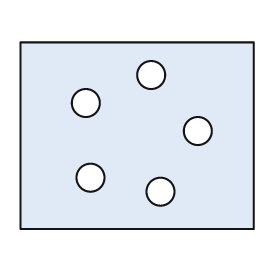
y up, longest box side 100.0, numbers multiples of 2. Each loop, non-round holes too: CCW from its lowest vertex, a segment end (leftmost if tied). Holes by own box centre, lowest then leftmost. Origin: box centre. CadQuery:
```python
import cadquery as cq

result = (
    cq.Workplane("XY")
    .moveTo(-50.0, -40.0)
    .lineTo(50.0, -40.0)
    .lineTo(50.0, 40.0)
    .lineTo(-50.0, 40.0)
    .close()
    .moveTo(10.0, -24.0)
    .circle(6.0)
    .moveTo(-20.0, -18.0)
    .circle(6.0)
    .moveTo(26.0, 2.0)
    .circle(6.0)
    .moveTo(-22.0, 14.0)
    .circle(6.0)
    .moveTo(6.0, 26.0)
    .circle(6.0)
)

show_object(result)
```